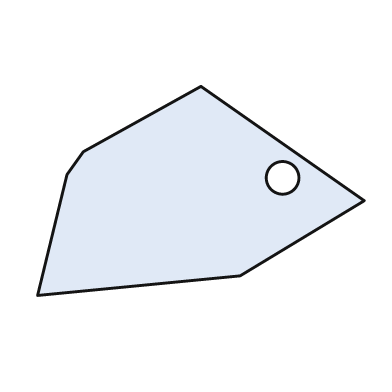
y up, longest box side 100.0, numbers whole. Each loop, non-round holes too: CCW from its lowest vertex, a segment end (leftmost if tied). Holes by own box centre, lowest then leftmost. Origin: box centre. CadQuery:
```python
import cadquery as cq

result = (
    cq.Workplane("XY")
    .moveTo(-50.0, -32.0)
    .lineTo(12.0, -26.0)
    .lineTo(50.0, -3.0)
    .lineTo(0.0, 32.0)
    .lineTo(-36.0, 12.0)
    .lineTo(-41.0, 5.0)
    .close()
    .moveTo(25.0, 4.0)
    .circle(5.0)
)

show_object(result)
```